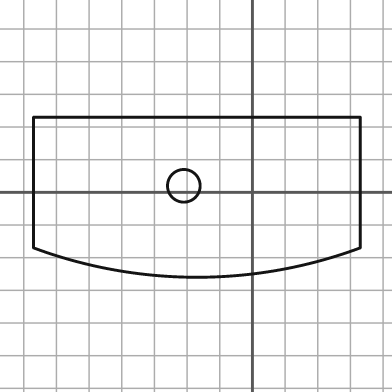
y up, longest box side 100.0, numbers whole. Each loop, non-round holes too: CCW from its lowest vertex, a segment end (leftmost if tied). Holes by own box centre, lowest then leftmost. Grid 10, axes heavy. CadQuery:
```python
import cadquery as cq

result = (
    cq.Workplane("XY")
    .moveTo(-67.0, -17.0)
    .threePointArc((-17.0, -26.0), (33.0, -17.0))
    .lineTo(33.0, 23.0)
    .lineTo(-67.0, 23.0)
    .close()
    .moveTo(-21.0, 2.0)
    .circle(5.0)
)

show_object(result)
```